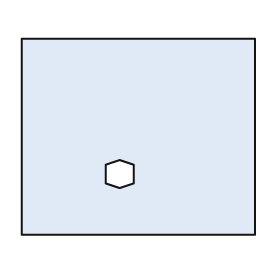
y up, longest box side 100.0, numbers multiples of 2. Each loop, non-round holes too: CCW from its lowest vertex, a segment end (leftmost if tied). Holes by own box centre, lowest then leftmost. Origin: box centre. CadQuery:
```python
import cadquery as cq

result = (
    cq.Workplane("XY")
    .moveTo(-50.0, -42.0)
    .lineTo(50.0, -42.0)
    .lineTo(50.0, 42.0)
    .lineTo(-50.0, 42.0)
    .close()
    .moveTo(-8.0, -22.0)
    .lineTo(-2.0, -20.0)
    .lineTo(-2.0, -12.0)
    .lineTo(-8.0, -10.0)
    .lineTo(-14.0, -12.0)
    .lineTo(-14.0, -20.0)
    .close()
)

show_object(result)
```